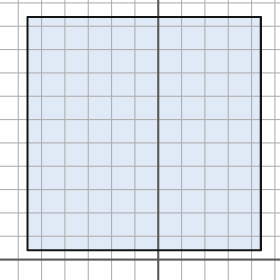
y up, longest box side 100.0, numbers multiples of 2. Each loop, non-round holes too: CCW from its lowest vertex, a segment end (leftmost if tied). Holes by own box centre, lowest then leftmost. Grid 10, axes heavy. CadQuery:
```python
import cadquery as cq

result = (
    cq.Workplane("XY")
    .moveTo(-56.0, 4.0)
    .lineTo(44.0, 4.0)
    .lineTo(44.0, 104.0)
    .lineTo(-56.0, 104.0)
    .close()
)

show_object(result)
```